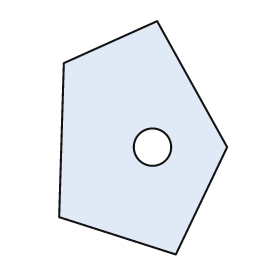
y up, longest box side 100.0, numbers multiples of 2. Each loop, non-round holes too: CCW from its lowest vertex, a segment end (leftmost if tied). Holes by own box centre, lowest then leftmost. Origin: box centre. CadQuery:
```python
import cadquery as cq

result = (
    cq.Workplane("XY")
    .moveTo(14.0, -50.0)
    .lineTo(36.0, -4.0)
    .lineTo(6.0, 50.0)
    .lineTo(-34.0, 32.0)
    .lineTo(-36.0, -34.0)
    .close()
    .moveTo(4.0, -4.0)
    .circle(8.0)
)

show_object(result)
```